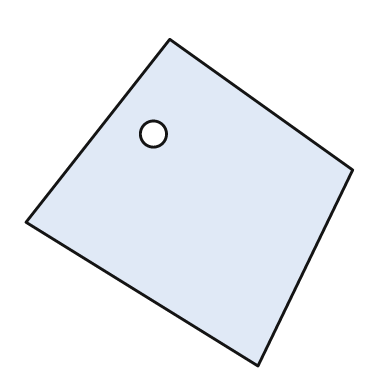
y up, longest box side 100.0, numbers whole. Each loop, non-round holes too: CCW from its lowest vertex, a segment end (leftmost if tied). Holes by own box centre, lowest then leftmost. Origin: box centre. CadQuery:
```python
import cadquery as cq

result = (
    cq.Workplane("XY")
    .moveTo(21.0, -50.0)
    .lineTo(50.0, 10.0)
    .lineTo(-6.0, 50.0)
    .lineTo(-50.0, -6.0)
    .close()
    .moveTo(-11.0, 21.0)
    .circle(4.0)
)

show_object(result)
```